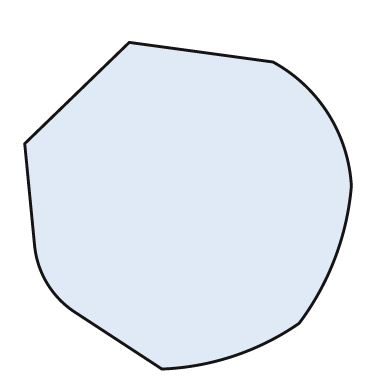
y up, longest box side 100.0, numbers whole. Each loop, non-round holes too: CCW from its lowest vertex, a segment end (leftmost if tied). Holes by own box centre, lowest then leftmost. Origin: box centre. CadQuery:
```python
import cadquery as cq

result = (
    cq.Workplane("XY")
    .moveTo(-8.0, -50.0)
    .threePointArc((14.0, -46.0), (34.0, -36.0))
    .threePointArc((45.0, -16.0), (50.0, 6.0))
    .threePointArc((43.0, 28.0), (26.0, 44.0))
    .lineTo(-18.0, 50.0)
    .lineTo(-50.0, 19.0)
    .lineTo(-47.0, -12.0)
    .threePointArc((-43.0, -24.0), (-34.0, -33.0))
    .close()
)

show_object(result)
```